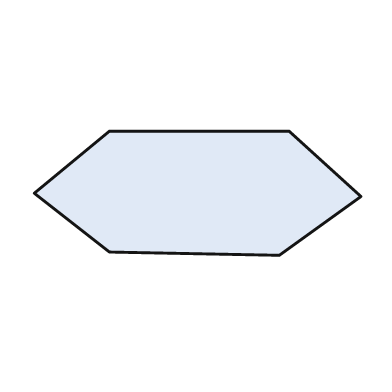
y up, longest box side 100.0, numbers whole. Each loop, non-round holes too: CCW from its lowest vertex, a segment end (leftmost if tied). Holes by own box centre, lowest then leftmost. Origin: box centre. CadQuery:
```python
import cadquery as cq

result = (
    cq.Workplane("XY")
    .moveTo(25.0, -19.0)
    .lineTo(50.0, -1.0)
    .lineTo(28.0, 19.0)
    .lineTo(-27.0, 19.0)
    .lineTo(-50.0, 0.0)
    .lineTo(-27.0, -18.0)
    .close()
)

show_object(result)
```